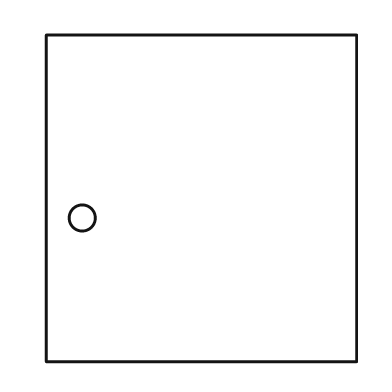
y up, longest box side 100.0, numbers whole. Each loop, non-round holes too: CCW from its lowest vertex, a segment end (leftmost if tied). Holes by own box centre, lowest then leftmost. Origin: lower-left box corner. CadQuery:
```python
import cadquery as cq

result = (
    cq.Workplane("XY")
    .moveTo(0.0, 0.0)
    .lineTo(95.0, 0.0)
    .lineTo(95.0, 100.0)
    .lineTo(0.0, 100.0)
    .close()
    .moveTo(11.0, 44.0)
    .circle(4.0)
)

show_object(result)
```